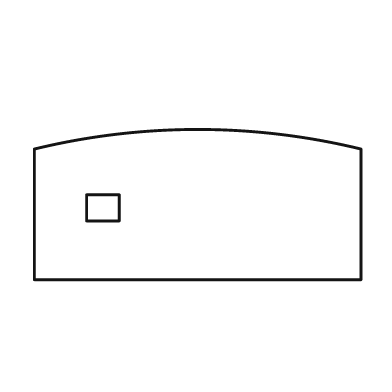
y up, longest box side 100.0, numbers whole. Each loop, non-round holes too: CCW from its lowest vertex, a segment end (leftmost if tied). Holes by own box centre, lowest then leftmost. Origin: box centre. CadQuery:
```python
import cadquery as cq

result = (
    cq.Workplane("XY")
    .moveTo(-50.0, -23.0)
    .lineTo(50.0, -23.0)
    .lineTo(50.0, 17.0)
    .threePointArc((0.0, 23.0), (-50.0, 17.0))
    .close()
    .moveTo(-34.0, -5.0)
    .lineTo(-24.0, -5.0)
    .lineTo(-24.0, 3.0)
    .lineTo(-34.0, 3.0)
    .close()
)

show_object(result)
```